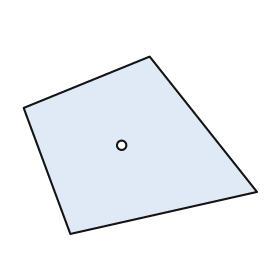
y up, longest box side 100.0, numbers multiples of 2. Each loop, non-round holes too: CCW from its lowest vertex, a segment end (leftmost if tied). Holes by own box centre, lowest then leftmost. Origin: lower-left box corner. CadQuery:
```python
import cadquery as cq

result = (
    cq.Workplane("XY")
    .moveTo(20.0, 0.0)
    .lineTo(100.0, 18.0)
    .lineTo(54.0, 76.0)
    .lineTo(0.0, 54.0)
    .close()
    .moveTo(42.0, 38.0)
    .circle(2.0)
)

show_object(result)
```